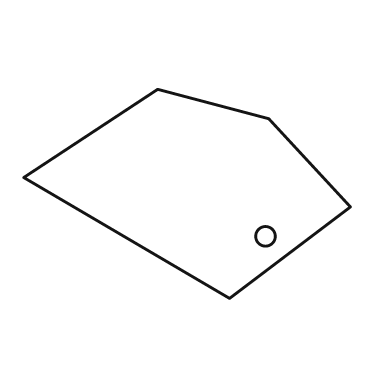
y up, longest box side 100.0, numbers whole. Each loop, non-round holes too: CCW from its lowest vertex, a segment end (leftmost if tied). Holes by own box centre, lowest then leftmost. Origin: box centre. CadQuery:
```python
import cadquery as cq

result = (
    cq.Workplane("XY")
    .moveTo(13.0, -32.0)
    .lineTo(50.0, -4.0)
    .lineTo(25.0, 23.0)
    .lineTo(-9.0, 32.0)
    .lineTo(-50.0, 5.0)
    .close()
    .moveTo(24.0, -13.0)
    .circle(3.0)
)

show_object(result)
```